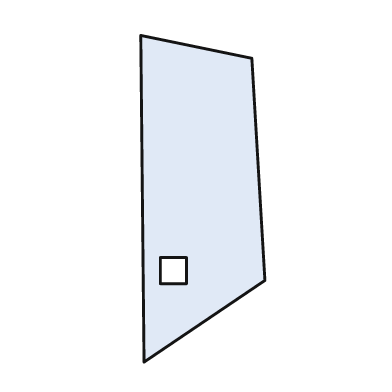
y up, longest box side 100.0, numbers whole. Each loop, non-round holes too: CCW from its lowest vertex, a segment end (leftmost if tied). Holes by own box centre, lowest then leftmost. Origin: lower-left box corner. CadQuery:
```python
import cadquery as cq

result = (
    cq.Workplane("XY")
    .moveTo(1.0, 0.0)
    .lineTo(38.0, 25.0)
    .lineTo(34.0, 93.0)
    .lineTo(0.0, 100.0)
    .close()
    .moveTo(6.0, 24.0)
    .lineTo(14.0, 24.0)
    .lineTo(14.0, 32.0)
    .lineTo(6.0, 32.0)
    .close()
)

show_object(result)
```